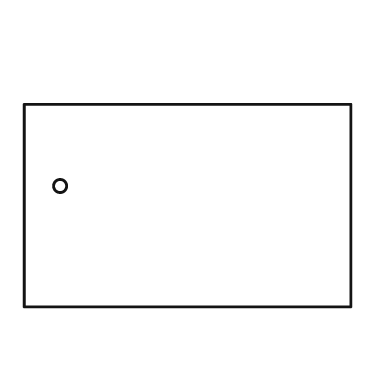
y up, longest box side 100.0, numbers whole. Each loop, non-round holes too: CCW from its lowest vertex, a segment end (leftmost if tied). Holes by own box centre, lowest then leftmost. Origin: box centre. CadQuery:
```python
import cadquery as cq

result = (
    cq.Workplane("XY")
    .moveTo(-50.0, -31.0)
    .lineTo(50.0, -31.0)
    .lineTo(50.0, 31.0)
    .lineTo(-50.0, 31.0)
    .close()
    .moveTo(-39.0, 6.0)
    .circle(2.0)
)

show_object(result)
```